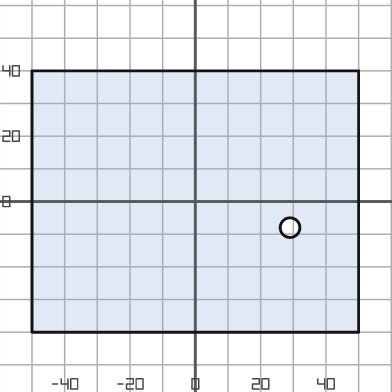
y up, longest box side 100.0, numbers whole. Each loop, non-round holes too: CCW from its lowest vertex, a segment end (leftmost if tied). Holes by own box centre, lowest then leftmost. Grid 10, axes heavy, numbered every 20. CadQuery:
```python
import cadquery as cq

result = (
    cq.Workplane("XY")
    .moveTo(-50.0, -40.0)
    .lineTo(50.0, -40.0)
    .lineTo(50.0, 40.0)
    .lineTo(-50.0, 40.0)
    .close()
    .moveTo(29.0, -8.0)
    .circle(3.0)
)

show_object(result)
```